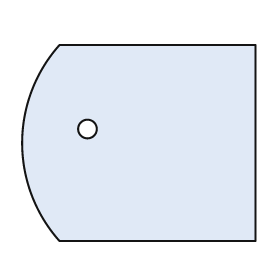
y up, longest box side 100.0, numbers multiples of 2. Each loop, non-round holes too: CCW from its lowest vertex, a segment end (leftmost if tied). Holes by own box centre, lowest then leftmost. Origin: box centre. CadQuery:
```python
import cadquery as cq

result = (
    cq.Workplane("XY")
    .moveTo(-34.0, -42.0)
    .lineTo(50.0, -42.0)
    .lineTo(50.0, 42.0)
    .lineTo(-34.0, 42.0)
    .threePointArc((-50.0, 0.0), (-34.0, -42.0))
    .close()
    .moveTo(-22.0, 6.0)
    .circle(4.0)
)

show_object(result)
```